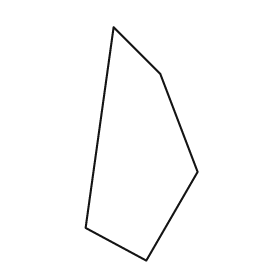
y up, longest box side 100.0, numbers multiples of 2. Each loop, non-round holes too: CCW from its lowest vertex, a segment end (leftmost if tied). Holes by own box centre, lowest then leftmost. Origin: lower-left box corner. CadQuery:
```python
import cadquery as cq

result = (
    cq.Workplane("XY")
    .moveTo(26.0, 0.0)
    .lineTo(48.0, 38.0)
    .lineTo(32.0, 80.0)
    .lineTo(12.0, 100.0)
    .lineTo(0.0, 14.0)
    .close()
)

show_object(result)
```